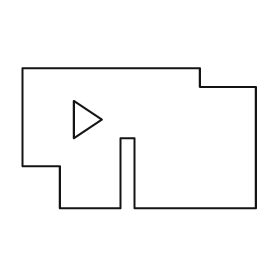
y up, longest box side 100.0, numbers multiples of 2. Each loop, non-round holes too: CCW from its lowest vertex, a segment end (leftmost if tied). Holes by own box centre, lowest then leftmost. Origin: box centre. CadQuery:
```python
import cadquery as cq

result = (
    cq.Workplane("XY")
    .moveTo(-34.0, -30.0)
    .lineTo(-8.0, -30.0)
    .lineTo(-8.0, 0.0)
    .lineTo(-2.0, 0.0)
    .lineTo(-2.0, -30.0)
    .lineTo(50.0, -30.0)
    .lineTo(50.0, 22.0)
    .lineTo(26.0, 22.0)
    .lineTo(26.0, 30.0)
    .lineTo(-50.0, 30.0)
    .lineTo(-50.0, -12.0)
    .lineTo(-34.0, -12.0)
    .close()
    .moveTo(-28.0, 0.0)
    .lineTo(-16.0, 8.0)
    .lineTo(-28.0, 16.0)
    .close()
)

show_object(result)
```